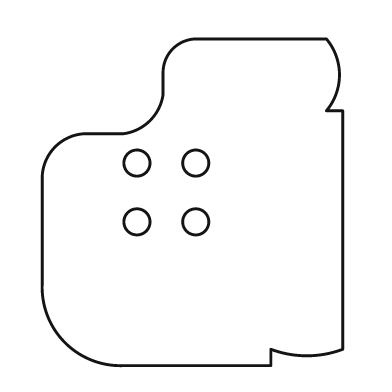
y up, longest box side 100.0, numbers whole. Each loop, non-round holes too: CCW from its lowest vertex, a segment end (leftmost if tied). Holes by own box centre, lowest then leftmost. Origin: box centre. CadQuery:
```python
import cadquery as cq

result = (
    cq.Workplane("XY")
    .moveTo(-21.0, -50.0)
    .lineTo(24.0, -50.0)
    .lineTo(24.0, -45.0)
    .threePointArc((35.0, -47.0), (46.0, -45.0))
    .lineTo(46.0, 28.0)
    .lineTo(41.0, 28.0)
    .threePointArc((45.0, 39.0), (41.0, 50.0))
    .lineTo(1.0, 50.0)
    .threePointArc((-6.0, 47.0), (-9.0, 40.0))
    .lineTo(-9.0, 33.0)
    .threePointArc((-13.0, 25.0), (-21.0, 21.0))
    .lineTo(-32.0, 21.0)
    .threePointArc((-42.0, 17.0), (-46.0, 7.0))
    .lineTo(-46.0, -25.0)
    .threePointArc((-39.0, -43.0), (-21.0, -50.0))
    .close()
    .moveTo(-17.0, -6.0)
    .circle(4.0)
    .moveTo(1.0, -6.0)
    .circle(4.0)
    .moveTo(-17.0, 12.0)
    .circle(4.0)
    .moveTo(1.0, 12.0)
    .circle(4.0)
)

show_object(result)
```